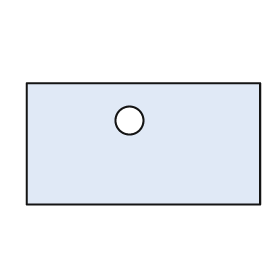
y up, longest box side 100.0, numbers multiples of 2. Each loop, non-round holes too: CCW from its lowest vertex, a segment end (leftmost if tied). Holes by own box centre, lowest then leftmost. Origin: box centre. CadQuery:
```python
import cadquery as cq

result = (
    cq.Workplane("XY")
    .moveTo(-50.0, -26.0)
    .lineTo(50.0, -26.0)
    .lineTo(50.0, 26.0)
    .lineTo(-50.0, 26.0)
    .close()
    .moveTo(-6.0, 10.0)
    .circle(6.0)
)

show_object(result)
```